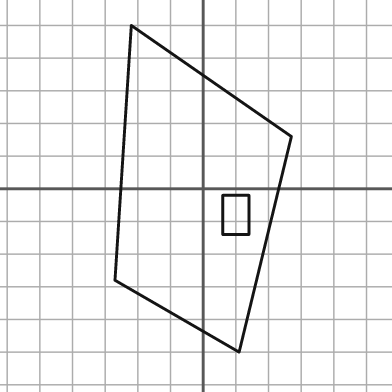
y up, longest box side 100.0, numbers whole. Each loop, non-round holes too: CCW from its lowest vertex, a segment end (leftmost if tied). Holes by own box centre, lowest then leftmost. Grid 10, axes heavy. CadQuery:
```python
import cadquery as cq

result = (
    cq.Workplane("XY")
    .moveTo(11.0, -50.0)
    .lineTo(27.0, 16.0)
    .lineTo(-22.0, 50.0)
    .lineTo(-27.0, -28.0)
    .close()
    .moveTo(6.0, -14.0)
    .lineTo(14.0, -14.0)
    .lineTo(14.0, -2.0)
    .lineTo(6.0, -2.0)
    .close()
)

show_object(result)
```